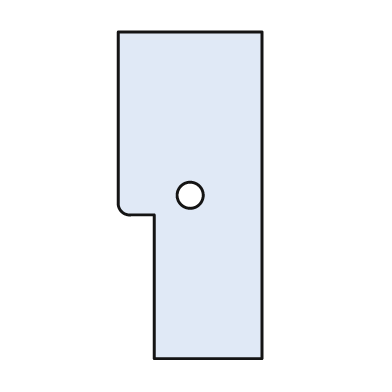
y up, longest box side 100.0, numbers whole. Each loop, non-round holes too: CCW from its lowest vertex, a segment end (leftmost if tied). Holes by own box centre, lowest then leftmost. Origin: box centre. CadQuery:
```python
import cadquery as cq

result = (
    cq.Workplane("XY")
    .moveTo(-11.0, -50.0)
    .lineTo(22.0, -50.0)
    .lineTo(22.0, 50.0)
    .lineTo(-22.0, 50.0)
    .lineTo(-22.0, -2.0)
    .threePointArc((-21.0, -5.0), (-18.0, -6.0))
    .lineTo(-11.0, -6.0)
    .close()
    .moveTo(0.0, 0.0)
    .circle(4.0)
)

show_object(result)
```